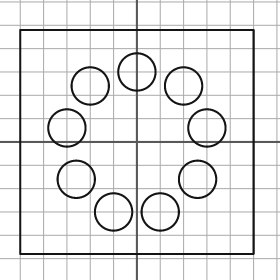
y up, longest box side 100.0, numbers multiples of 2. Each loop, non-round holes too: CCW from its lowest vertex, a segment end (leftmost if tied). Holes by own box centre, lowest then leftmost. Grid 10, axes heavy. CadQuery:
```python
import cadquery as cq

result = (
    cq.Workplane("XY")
    .moveTo(-50.0, -48.0)
    .lineTo(50.0, -48.0)
    .lineTo(50.0, 48.0)
    .lineTo(-50.0, 48.0)
    .close()
    .moveTo(-10.0, -30.0)
    .circle(8.0)
    .moveTo(10.0, -30.0)
    .circle(8.0)
    .moveTo(-26.0, -16.0)
    .circle(8.0)
    .moveTo(26.0, -16.0)
    .circle(8.0)
    .moveTo(-30.0, 6.0)
    .circle(8.0)
    .moveTo(30.0, 6.0)
    .circle(8.0)
    .moveTo(-20.0, 24.0)
    .circle(8.0)
    .moveTo(20.0, 24.0)
    .circle(8.0)
    .moveTo(0.0, 30.0)
    .circle(8.0)
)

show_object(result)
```